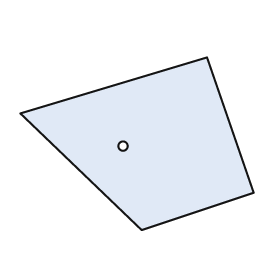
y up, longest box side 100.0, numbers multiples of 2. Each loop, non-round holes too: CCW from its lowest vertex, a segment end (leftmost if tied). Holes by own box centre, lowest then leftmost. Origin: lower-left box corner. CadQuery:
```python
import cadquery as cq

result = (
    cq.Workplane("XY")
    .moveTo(52.0, 0.0)
    .lineTo(100.0, 16.0)
    .lineTo(80.0, 74.0)
    .lineTo(0.0, 50.0)
    .close()
    .moveTo(44.0, 36.0)
    .circle(2.0)
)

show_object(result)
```